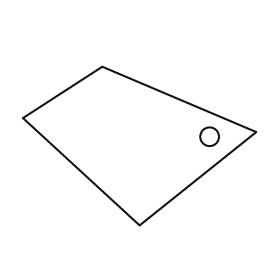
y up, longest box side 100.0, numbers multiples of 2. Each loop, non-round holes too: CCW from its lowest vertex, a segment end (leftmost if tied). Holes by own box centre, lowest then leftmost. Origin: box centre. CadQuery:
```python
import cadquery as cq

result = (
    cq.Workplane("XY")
    .moveTo(0.0, -34.0)
    .lineTo(50.0, 6.0)
    .lineTo(-16.0, 34.0)
    .lineTo(-50.0, 12.0)
    .close()
    .moveTo(30.0, 4.0)
    .circle(4.0)
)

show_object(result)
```